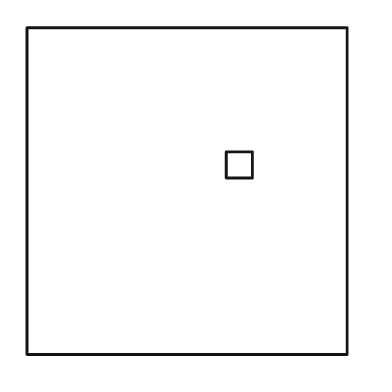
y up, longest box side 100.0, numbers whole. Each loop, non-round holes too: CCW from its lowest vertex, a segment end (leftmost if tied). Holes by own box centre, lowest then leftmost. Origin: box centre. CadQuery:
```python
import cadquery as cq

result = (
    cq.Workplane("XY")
    .moveTo(-49.0, -50.0)
    .lineTo(49.0, -50.0)
    .lineTo(49.0, 50.0)
    .lineTo(-49.0, 50.0)
    .close()
    .moveTo(12.0, 4.0)
    .lineTo(20.0, 4.0)
    .lineTo(20.0, 12.0)
    .lineTo(12.0, 12.0)
    .close()
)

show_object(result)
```